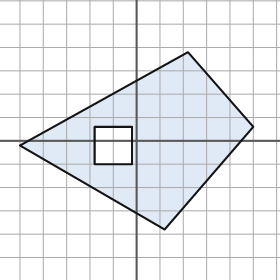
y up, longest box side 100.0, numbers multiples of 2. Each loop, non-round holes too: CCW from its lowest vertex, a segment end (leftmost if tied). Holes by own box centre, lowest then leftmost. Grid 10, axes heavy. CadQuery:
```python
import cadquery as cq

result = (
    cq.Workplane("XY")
    .moveTo(12.0, -38.0)
    .lineTo(50.0, 6.0)
    .lineTo(22.0, 38.0)
    .lineTo(-50.0, -2.0)
    .close()
    .moveTo(-18.0, -10.0)
    .lineTo(-2.0, -10.0)
    .lineTo(-2.0, 6.0)
    .lineTo(-18.0, 6.0)
    .close()
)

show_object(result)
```